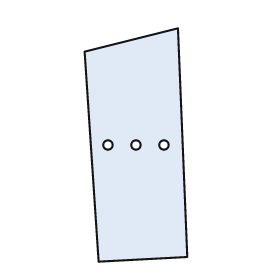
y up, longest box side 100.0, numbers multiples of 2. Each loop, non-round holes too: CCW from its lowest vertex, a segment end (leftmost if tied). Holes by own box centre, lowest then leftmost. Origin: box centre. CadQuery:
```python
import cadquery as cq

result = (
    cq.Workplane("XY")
    .moveTo(-16.0, -50.0)
    .lineTo(22.0, -48.0)
    .lineTo(18.0, 50.0)
    .lineTo(-22.0, 40.0)
    .close()
    .moveTo(-12.0, 0.0)
    .circle(2.0)
    .moveTo(0.0, 0.0)
    .circle(2.0)
    .moveTo(12.0, 0.0)
    .circle(2.0)
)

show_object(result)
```